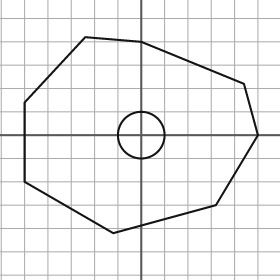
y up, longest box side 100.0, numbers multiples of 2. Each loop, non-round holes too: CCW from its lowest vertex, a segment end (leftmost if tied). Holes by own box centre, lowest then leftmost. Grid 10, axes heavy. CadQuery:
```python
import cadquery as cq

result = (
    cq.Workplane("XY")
    .moveTo(-12.0, -42.0)
    .lineTo(32.0, -30.0)
    .lineTo(50.0, 0.0)
    .lineTo(44.0, 22.0)
    .lineTo(0.0, 40.0)
    .lineTo(-24.0, 42.0)
    .lineTo(-50.0, 14.0)
    .lineTo(-50.0, -20.0)
    .close()
    .moveTo(0.0, 0.0)
    .circle(10.0)
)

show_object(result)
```